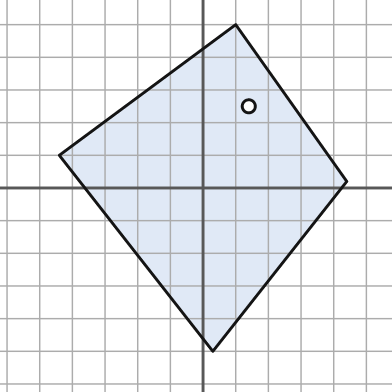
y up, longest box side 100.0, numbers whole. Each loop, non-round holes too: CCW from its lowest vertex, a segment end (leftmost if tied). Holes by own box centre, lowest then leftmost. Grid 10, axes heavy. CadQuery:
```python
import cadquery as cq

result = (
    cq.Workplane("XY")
    .moveTo(3.0, -50.0)
    .lineTo(44.0, 2.0)
    .lineTo(10.0, 50.0)
    .lineTo(-44.0, 10.0)
    .close()
    .moveTo(14.0, 25.0)
    .circle(2.0)
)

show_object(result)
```